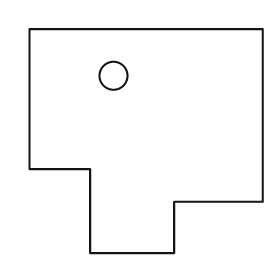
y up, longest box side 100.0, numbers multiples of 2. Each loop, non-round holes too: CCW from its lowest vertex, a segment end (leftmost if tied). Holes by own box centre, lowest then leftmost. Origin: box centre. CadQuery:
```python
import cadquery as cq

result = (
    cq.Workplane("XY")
    .moveTo(-24.0, -48.0)
    .lineTo(12.0, -48.0)
    .lineTo(12.0, -26.0)
    .lineTo(50.0, -26.0)
    .lineTo(50.0, 48.0)
    .lineTo(-50.0, 48.0)
    .lineTo(-50.0, -12.0)
    .lineTo(-24.0, -12.0)
    .close()
    .moveTo(-14.0, 28.0)
    .circle(6.0)
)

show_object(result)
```